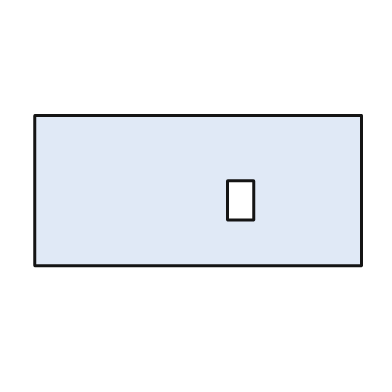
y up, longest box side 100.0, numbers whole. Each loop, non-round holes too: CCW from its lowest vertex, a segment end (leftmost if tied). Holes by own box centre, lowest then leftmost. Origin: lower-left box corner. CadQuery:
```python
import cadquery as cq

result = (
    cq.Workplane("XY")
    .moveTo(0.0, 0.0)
    .lineTo(100.0, 0.0)
    .lineTo(100.0, 46.0)
    .lineTo(0.0, 46.0)
    .close()
    .moveTo(59.0, 14.0)
    .lineTo(67.0, 14.0)
    .lineTo(67.0, 26.0)
    .lineTo(59.0, 26.0)
    .close()
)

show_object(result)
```